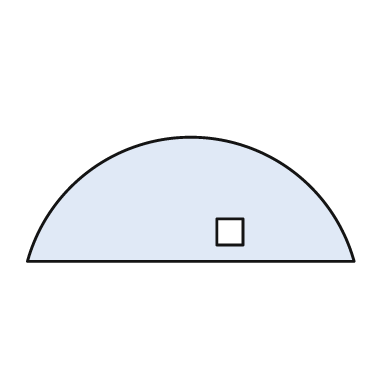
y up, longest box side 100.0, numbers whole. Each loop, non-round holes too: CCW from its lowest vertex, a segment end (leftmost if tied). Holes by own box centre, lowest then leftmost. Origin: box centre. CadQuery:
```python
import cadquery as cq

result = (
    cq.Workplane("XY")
    .moveTo(-50.0, -19.0)
    .lineTo(50.0, -19.0)
    .threePointArc((0.0, 19.0), (-50.0, -19.0))
    .close()
    .moveTo(8.0, -14.0)
    .lineTo(16.0, -14.0)
    .lineTo(16.0, -6.0)
    .lineTo(8.0, -6.0)
    .close()
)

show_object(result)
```